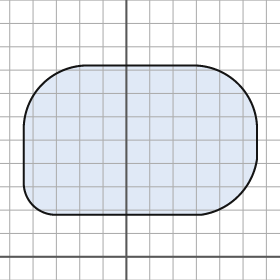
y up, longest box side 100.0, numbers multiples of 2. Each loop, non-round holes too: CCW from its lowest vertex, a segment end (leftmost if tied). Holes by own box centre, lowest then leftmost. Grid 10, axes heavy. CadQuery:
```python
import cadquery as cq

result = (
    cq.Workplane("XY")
    .moveTo(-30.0, 18.0)
    .lineTo(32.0, 18.0)
    .threePointArc((48.0, 26.0), (56.0, 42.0))
    .lineTo(56.0, 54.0)
    .threePointArc((48.0, 74.0), (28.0, 82.0))
    .lineTo(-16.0, 82.0)
    .threePointArc((-36.0, 74.0), (-44.0, 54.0))
    .lineTo(-44.0, 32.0)
    .threePointArc((-40.0, 22.0), (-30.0, 18.0))
    .close()
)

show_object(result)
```